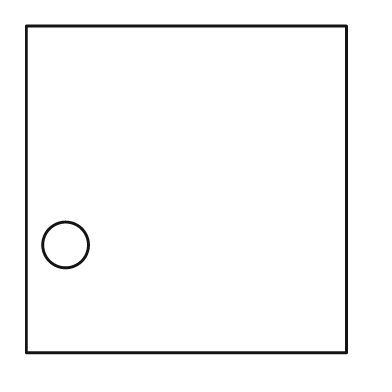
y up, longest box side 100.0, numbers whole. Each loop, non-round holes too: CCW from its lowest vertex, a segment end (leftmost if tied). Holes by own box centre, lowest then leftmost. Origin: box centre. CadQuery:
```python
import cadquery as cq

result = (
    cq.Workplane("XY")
    .moveTo(-49.0, -50.0)
    .lineTo(49.0, -50.0)
    .lineTo(49.0, 50.0)
    .lineTo(-49.0, 50.0)
    .close()
    .moveTo(-37.0, -17.0)
    .circle(7.0)
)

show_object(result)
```